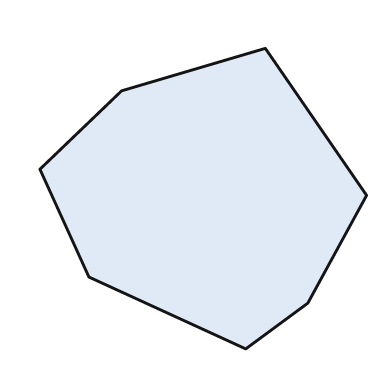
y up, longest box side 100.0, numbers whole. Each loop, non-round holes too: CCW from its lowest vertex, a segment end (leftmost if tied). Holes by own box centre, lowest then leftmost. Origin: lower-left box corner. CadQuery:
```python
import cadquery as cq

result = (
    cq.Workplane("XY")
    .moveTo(63.0, 0.0)
    .lineTo(82.0, 14.0)
    .lineTo(100.0, 47.0)
    .lineTo(69.0, 92.0)
    .lineTo(25.0, 79.0)
    .lineTo(0.0, 55.0)
    .lineTo(15.0, 22.0)
    .close()
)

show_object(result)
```